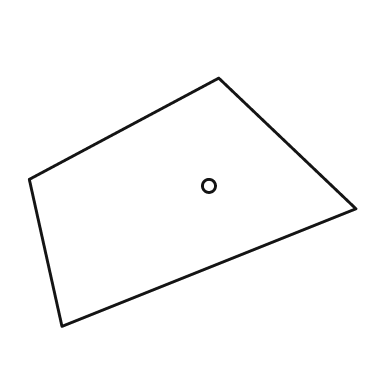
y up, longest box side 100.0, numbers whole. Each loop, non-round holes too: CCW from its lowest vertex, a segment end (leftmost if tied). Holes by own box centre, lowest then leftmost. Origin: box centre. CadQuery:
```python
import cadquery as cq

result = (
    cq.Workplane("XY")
    .moveTo(-40.0, -38.0)
    .lineTo(50.0, -2.0)
    .lineTo(8.0, 38.0)
    .lineTo(-50.0, 7.0)
    .close()
    .moveTo(5.0, 5.0)
    .circle(2.0)
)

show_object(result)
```